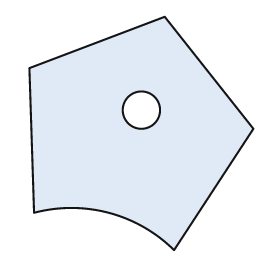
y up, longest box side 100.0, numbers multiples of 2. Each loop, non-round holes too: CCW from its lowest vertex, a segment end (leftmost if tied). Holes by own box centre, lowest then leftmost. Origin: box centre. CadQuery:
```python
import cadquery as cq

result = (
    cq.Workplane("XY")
    .moveTo(14.0, -50.0)
    .lineTo(48.0, 2.0)
    .lineTo(10.0, 50.0)
    .lineTo(-48.0, 28.0)
    .lineTo(-46.0, -34.0)
    .threePointArc((-14.0, -34.0), (14.0, -50.0))
    .close()
    .moveTo(0.0, 10.0)
    .circle(8.0)
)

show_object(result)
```